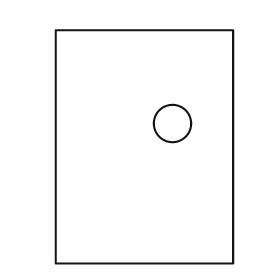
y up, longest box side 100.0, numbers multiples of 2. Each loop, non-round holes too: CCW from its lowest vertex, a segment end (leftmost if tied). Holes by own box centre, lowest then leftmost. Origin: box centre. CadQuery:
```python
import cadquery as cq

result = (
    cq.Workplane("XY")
    .moveTo(-38.0, -50.0)
    .lineTo(38.0, -50.0)
    .lineTo(38.0, 50.0)
    .lineTo(-38.0, 50.0)
    .close()
    .moveTo(12.0, 10.0)
    .circle(8.0)
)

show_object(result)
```